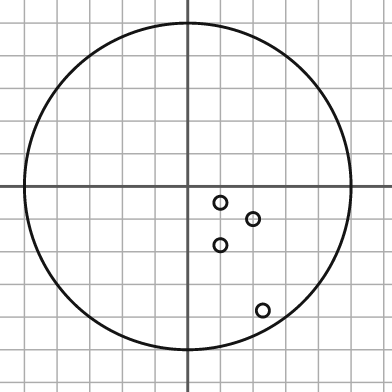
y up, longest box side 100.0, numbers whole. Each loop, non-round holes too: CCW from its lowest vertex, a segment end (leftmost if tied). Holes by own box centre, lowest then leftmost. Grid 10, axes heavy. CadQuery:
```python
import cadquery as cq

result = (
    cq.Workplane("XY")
    .moveTo(0.0, 0.0)
    .circle(50.0)
    .moveTo(23.0, -38.0)
    .circle(2.0)
    .moveTo(10.0, -18.0)
    .circle(2.0)
    .moveTo(20.0, -10.0)
    .circle(2.0)
    .moveTo(10.0, -5.0)
    .circle(2.0)
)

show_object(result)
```